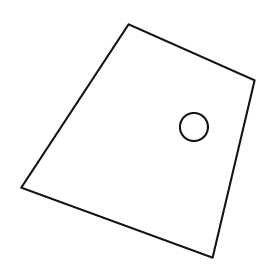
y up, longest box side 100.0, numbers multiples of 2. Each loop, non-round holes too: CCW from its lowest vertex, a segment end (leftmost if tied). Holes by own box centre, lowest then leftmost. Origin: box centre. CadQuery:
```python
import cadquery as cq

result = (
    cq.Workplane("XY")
    .moveTo(32.0, -50.0)
    .lineTo(50.0, 26.0)
    .lineTo(-4.0, 50.0)
    .lineTo(-50.0, -20.0)
    .close()
    .moveTo(24.0, 6.0)
    .circle(6.0)
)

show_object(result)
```